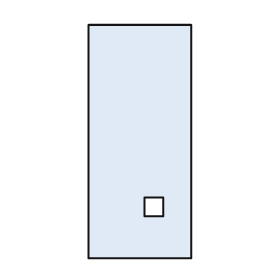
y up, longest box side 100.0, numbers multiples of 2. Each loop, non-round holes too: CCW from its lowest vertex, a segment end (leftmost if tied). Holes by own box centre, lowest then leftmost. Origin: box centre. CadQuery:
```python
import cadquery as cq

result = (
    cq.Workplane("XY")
    .moveTo(-22.0, -50.0)
    .lineTo(22.0, -50.0)
    .lineTo(22.0, 50.0)
    .lineTo(-22.0, 50.0)
    .close()
    .moveTo(2.0, -32.0)
    .lineTo(10.0, -32.0)
    .lineTo(10.0, -24.0)
    .lineTo(2.0, -24.0)
    .close()
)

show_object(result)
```